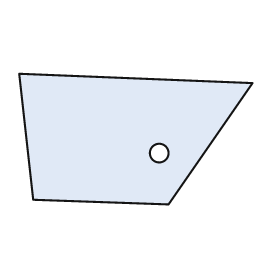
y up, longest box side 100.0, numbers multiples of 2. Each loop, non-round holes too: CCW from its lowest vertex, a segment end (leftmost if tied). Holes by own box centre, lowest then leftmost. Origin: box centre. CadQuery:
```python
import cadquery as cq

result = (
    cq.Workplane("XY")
    .moveTo(14.0, -28.0)
    .lineTo(50.0, 24.0)
    .lineTo(-50.0, 28.0)
    .lineTo(-44.0, -26.0)
    .close()
    .moveTo(10.0, -6.0)
    .circle(4.0)
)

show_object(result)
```